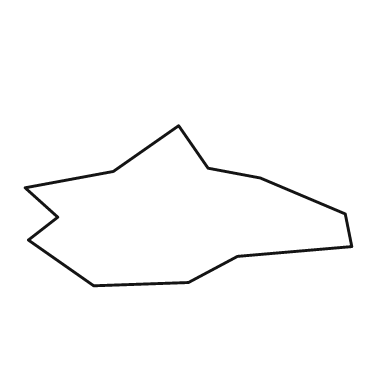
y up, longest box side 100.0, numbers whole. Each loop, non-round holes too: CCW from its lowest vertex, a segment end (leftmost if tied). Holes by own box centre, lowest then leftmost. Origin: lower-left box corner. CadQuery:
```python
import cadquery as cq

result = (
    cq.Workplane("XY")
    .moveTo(21.0, 0.0)
    .lineTo(50.0, 1.0)
    .lineTo(65.0, 9.0)
    .lineTo(100.0, 12.0)
    .lineTo(98.0, 22.0)
    .lineTo(72.0, 33.0)
    .lineTo(56.0, 36.0)
    .lineTo(47.0, 49.0)
    .lineTo(27.0, 35.0)
    .lineTo(0.0, 30.0)
    .lineTo(10.0, 21.0)
    .lineTo(1.0, 14.0)
    .close()
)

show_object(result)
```